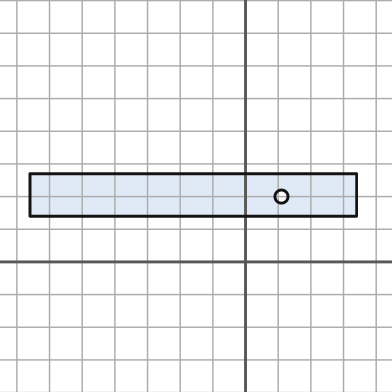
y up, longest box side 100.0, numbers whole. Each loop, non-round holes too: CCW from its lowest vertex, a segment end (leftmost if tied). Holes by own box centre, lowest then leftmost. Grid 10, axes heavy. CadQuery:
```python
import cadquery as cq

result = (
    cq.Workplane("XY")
    .moveTo(-66.0, 14.0)
    .lineTo(34.0, 14.0)
    .lineTo(34.0, 27.0)
    .lineTo(-66.0, 27.0)
    .close()
    .moveTo(11.0, 20.0)
    .circle(2.0)
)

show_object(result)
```